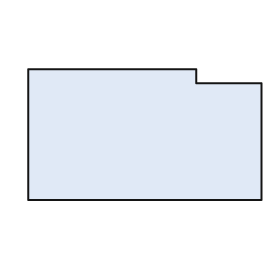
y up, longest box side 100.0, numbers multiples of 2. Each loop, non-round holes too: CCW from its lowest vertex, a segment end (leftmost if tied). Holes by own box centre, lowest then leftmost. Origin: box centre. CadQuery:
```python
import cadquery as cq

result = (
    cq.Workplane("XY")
    .moveTo(-50.0, -28.0)
    .lineTo(50.0, -28.0)
    .lineTo(50.0, 22.0)
    .lineTo(22.0, 22.0)
    .lineTo(22.0, 28.0)
    .lineTo(-50.0, 28.0)
    .close()
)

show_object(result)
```